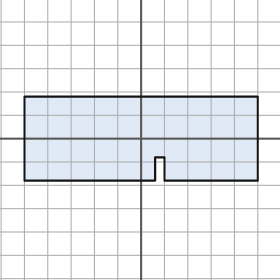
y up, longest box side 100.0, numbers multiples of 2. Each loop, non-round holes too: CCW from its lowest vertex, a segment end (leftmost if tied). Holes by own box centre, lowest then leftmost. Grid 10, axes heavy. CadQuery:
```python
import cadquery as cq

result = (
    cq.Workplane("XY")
    .moveTo(-50.0, -18.0)
    .lineTo(6.0, -18.0)
    .lineTo(6.0, -8.0)
    .lineTo(10.0, -8.0)
    .lineTo(10.0, -18.0)
    .lineTo(50.0, -18.0)
    .lineTo(50.0, 18.0)
    .lineTo(-50.0, 18.0)
    .close()
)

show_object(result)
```